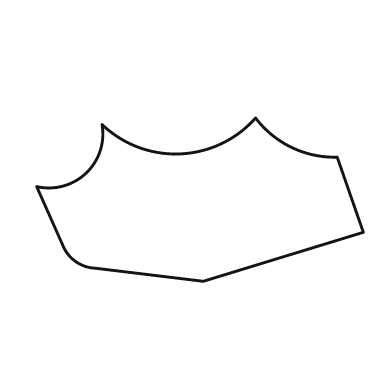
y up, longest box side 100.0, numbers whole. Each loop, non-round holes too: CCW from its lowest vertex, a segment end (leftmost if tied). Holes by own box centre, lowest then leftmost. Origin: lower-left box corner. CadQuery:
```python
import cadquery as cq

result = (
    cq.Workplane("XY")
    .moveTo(51.0, 0.0)
    .lineTo(100.0, 15.0)
    .lineTo(92.0, 38.0)
    .threePointArc((78.0, 41.0), (67.0, 50.0))
    .threePointArc((44.0, 39.0), (20.0, 48.0))
    .threePointArc((15.0, 33.0), (0.0, 29.0))
    .lineTo(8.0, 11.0)
    .threePointArc((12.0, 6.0), (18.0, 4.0))
    .close()
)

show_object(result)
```